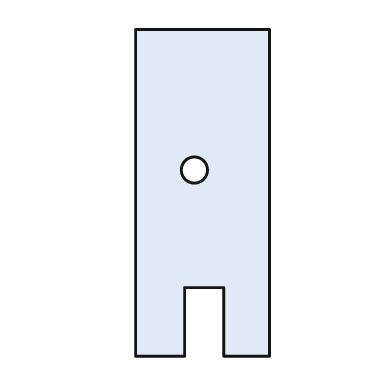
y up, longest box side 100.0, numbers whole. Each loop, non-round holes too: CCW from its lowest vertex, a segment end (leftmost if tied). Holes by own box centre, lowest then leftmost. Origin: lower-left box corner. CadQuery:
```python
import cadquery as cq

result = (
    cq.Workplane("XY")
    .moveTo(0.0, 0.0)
    .lineTo(15.0, 0.0)
    .lineTo(15.0, 21.0)
    .lineTo(27.0, 21.0)
    .lineTo(27.0, 0.0)
    .lineTo(41.0, 0.0)
    .lineTo(41.0, 100.0)
    .lineTo(0.0, 100.0)
    .close()
    .moveTo(18.0, 57.0)
    .circle(4.0)
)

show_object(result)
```